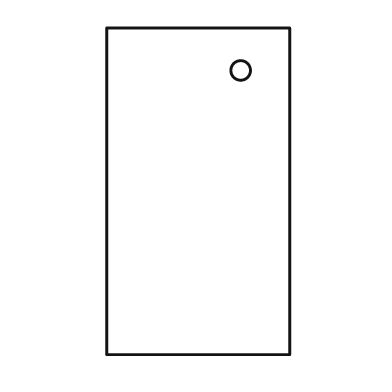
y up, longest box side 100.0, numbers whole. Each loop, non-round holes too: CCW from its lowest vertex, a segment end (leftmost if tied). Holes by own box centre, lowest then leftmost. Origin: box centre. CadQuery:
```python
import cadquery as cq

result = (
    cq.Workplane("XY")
    .moveTo(-28.0, -50.0)
    .lineTo(28.0, -50.0)
    .lineTo(28.0, 50.0)
    .lineTo(-28.0, 50.0)
    .close()
    .moveTo(13.0, 37.0)
    .circle(3.0)
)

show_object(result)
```